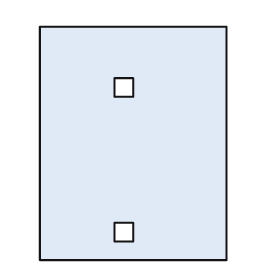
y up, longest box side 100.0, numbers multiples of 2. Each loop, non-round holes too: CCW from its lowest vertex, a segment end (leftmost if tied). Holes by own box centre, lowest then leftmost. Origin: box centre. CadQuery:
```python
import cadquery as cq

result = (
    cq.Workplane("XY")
    .moveTo(-40.0, -50.0)
    .lineTo(40.0, -50.0)
    .lineTo(40.0, 50.0)
    .lineTo(-40.0, 50.0)
    .close()
    .moveTo(-8.0, -42.0)
    .lineTo(0.0, -42.0)
    .lineTo(0.0, -34.0)
    .lineTo(-8.0, -34.0)
    .close()
    .moveTo(-8.0, 20.0)
    .lineTo(0.0, 20.0)
    .lineTo(0.0, 28.0)
    .lineTo(-8.0, 28.0)
    .close()
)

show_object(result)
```